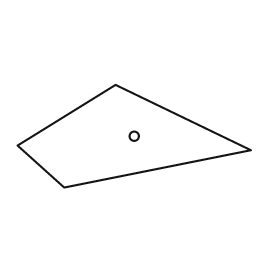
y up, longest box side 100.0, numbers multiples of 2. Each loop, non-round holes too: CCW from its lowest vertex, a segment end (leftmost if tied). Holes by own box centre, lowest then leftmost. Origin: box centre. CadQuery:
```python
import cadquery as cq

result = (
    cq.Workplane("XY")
    .moveTo(-30.0, -22.0)
    .lineTo(50.0, -6.0)
    .lineTo(-8.0, 22.0)
    .lineTo(-50.0, -4.0)
    .close()
    .moveTo(0.0, 0.0)
    .circle(2.0)
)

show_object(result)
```